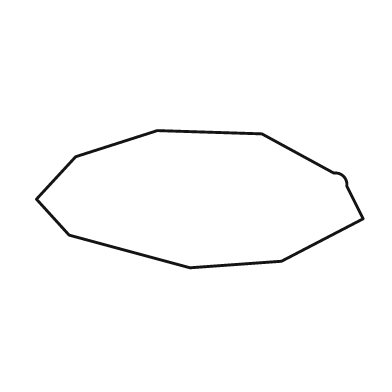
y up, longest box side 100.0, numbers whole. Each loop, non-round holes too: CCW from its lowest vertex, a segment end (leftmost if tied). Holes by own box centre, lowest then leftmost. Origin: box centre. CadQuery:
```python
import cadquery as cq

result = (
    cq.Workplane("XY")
    .moveTo(-3.0, -21.0)
    .lineTo(25.0, -19.0)
    .lineTo(50.0, -6.0)
    .lineTo(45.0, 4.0)
    .threePointArc((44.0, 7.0), (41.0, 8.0))
    .lineTo(19.0, 20.0)
    .lineTo(-13.0, 21.0)
    .lineTo(-38.0, 13.0)
    .lineTo(-50.0, 0.0)
    .lineTo(-40.0, -11.0)
    .close()
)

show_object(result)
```